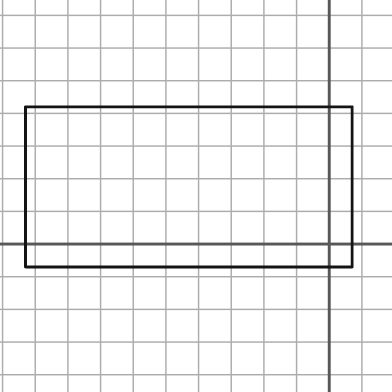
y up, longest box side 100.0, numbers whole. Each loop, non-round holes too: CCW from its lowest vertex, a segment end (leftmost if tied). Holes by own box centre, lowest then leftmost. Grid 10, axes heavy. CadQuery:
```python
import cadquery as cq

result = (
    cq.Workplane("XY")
    .moveTo(-93.0, -7.0)
    .lineTo(7.0, -7.0)
    .lineTo(7.0, 42.0)
    .lineTo(-93.0, 42.0)
    .close()
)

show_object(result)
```